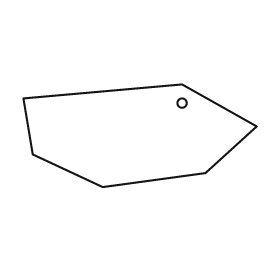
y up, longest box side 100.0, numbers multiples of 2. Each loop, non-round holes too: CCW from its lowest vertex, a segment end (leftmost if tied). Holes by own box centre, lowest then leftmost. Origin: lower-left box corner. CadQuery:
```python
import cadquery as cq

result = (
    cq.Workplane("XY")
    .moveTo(34.0, 0.0)
    .lineTo(78.0, 6.0)
    .lineTo(100.0, 26.0)
    .lineTo(68.0, 44.0)
    .lineTo(0.0, 38.0)
    .lineTo(4.0, 14.0)
    .close()
    .moveTo(68.0, 36.0)
    .circle(2.0)
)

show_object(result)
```